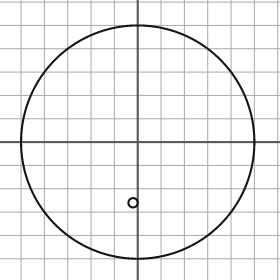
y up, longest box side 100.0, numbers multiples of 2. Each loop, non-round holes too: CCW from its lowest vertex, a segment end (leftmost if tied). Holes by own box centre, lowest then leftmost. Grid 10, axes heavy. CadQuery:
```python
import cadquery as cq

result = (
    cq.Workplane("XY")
    .moveTo(0.0, 0.0)
    .circle(50.0)
    .moveTo(-2.0, -26.0)
    .circle(2.0)
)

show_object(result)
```